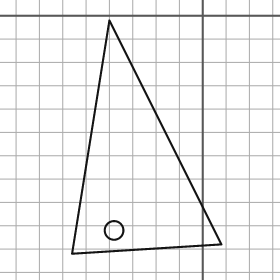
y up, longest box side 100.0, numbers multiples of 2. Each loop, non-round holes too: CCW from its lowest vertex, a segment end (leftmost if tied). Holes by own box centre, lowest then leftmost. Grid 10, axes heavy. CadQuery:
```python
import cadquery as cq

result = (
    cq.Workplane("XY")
    .moveTo(-56.0, -102.0)
    .lineTo(8.0, -98.0)
    .lineTo(-40.0, -2.0)
    .close()
    .moveTo(-38.0, -92.0)
    .circle(4.0)
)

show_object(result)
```